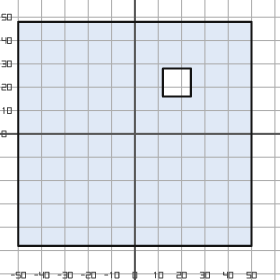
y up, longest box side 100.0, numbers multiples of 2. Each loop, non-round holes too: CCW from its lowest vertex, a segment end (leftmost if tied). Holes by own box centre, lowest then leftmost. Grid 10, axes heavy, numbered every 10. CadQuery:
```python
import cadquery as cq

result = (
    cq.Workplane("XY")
    .moveTo(-50.0, -48.0)
    .lineTo(50.0, -48.0)
    .lineTo(50.0, 48.0)
    .lineTo(-50.0, 48.0)
    .close()
    .moveTo(12.0, 16.0)
    .lineTo(24.0, 16.0)
    .lineTo(24.0, 28.0)
    .lineTo(12.0, 28.0)
    .close()
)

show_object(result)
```